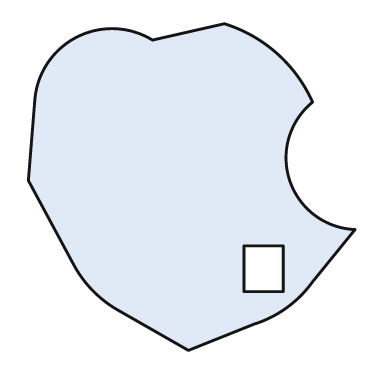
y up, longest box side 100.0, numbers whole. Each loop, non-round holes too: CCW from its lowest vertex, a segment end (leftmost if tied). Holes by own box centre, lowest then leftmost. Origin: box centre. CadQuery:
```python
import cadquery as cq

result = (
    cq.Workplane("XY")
    .moveTo(-1.0, -50.0)
    .lineTo(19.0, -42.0)
    .threePointArc((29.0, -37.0), (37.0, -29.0))
    .lineTo(50.0, -13.0)
    .threePointArc((30.0, 2.0), (37.0, 26.0))
    .threePointArc((26.0, 41.0), (10.0, 50.0))
    .lineTo(-12.0, 45.0)
    .threePointArc((-35.0, 46.0), (-48.0, 27.0))
    .lineTo(-50.0, 2.0)
    .lineTo(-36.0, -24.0)
    .threePointArc((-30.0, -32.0), (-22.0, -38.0))
    .close()
    .moveTo(16.0, -32.0)
    .lineTo(28.0, -32.0)
    .lineTo(28.0, -18.0)
    .lineTo(16.0, -18.0)
    .close()
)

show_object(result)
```